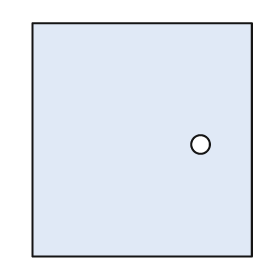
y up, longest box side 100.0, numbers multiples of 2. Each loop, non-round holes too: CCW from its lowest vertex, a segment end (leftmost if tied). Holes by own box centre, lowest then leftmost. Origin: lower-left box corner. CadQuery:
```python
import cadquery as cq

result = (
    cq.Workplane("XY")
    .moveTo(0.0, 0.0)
    .lineTo(94.0, 0.0)
    .lineTo(94.0, 100.0)
    .lineTo(0.0, 100.0)
    .close()
    .moveTo(72.0, 48.0)
    .circle(4.0)
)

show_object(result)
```